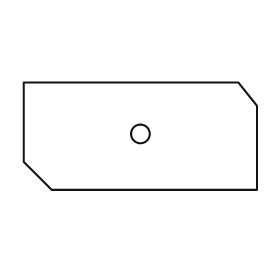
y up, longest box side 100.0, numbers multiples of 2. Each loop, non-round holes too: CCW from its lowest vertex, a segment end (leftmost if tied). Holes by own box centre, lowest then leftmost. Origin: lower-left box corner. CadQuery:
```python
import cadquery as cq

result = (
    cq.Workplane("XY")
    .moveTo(12.0, 0.0)
    .lineTo(100.0, 0.0)
    .lineTo(100.0, 36.0)
    .lineTo(92.0, 46.0)
    .lineTo(0.0, 46.0)
    .lineTo(0.0, 12.0)
    .close()
    .moveTo(50.0, 24.0)
    .circle(4.0)
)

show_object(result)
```